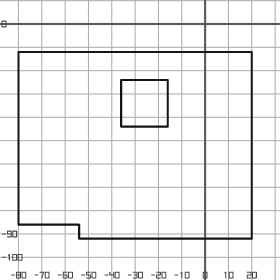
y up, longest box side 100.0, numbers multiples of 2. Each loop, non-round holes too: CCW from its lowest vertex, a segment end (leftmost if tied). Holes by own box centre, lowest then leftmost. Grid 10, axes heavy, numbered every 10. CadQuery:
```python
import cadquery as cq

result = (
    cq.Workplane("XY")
    .moveTo(-54.0, -92.0)
    .lineTo(20.0, -92.0)
    .lineTo(20.0, -12.0)
    .lineTo(-80.0, -12.0)
    .lineTo(-80.0, -86.0)
    .lineTo(-54.0, -86.0)
    .close()
    .moveTo(-36.0, -44.0)
    .lineTo(-16.0, -44.0)
    .lineTo(-16.0, -24.0)
    .lineTo(-36.0, -24.0)
    .close()
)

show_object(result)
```